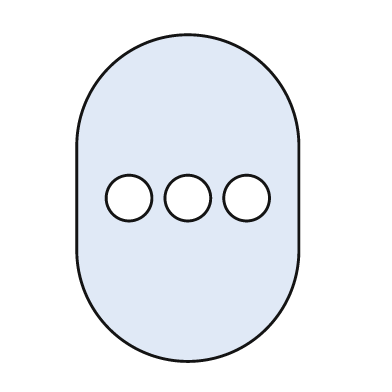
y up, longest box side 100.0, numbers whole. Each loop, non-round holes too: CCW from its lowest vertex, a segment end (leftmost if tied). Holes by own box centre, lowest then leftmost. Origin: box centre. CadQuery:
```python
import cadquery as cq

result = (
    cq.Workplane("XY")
    .moveTo(-34.0, -16.0)
    .threePointArc((0.0, -50.0), (34.0, -16.0))
    .lineTo(34.0, 16.0)
    .threePointArc((0.0, 50.0), (-34.0, 16.0))
    .close()
    .moveTo(-18.0, 0.0)
    .circle(7.0)
    .moveTo(0.0, 0.0)
    .circle(7.0)
    .moveTo(18.0, 0.0)
    .circle(7.0)
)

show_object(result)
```